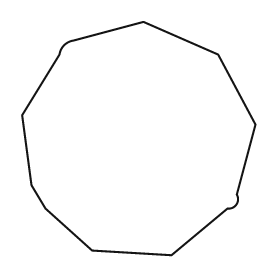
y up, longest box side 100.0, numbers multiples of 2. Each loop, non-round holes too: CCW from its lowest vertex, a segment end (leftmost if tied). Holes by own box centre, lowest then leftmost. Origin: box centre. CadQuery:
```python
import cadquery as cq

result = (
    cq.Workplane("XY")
    .moveTo(14.0, -50.0)
    .lineTo(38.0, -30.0)
    .threePointArc((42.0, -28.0), (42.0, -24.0))
    .lineTo(50.0, 6.0)
    .lineTo(34.0, 36.0)
    .lineTo(2.0, 50.0)
    .lineTo(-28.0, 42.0)
    .threePointArc((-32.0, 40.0), (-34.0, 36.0))
    .lineTo(-50.0, 10.0)
    .lineTo(-46.0, -20.0)
    .lineTo(-40.0, -30.0)
    .lineTo(-20.0, -48.0)
    .close()
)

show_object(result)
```